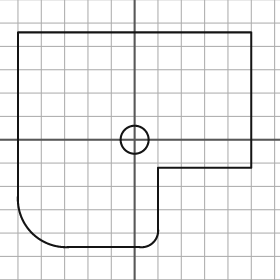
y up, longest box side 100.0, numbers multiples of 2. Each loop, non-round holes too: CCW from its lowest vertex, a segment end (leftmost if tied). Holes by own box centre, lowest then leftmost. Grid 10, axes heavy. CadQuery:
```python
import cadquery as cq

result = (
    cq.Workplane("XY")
    .moveTo(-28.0, -46.0)
    .lineTo(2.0, -46.0)
    .threePointArc((8.0, -44.0), (10.0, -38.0))
    .lineTo(10.0, -12.0)
    .lineTo(50.0, -12.0)
    .lineTo(50.0, 46.0)
    .lineTo(-50.0, 46.0)
    .lineTo(-50.0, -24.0)
    .threePointArc((-44.0, -40.0), (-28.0, -46.0))
    .close()
    .moveTo(0.0, 0.0)
    .circle(6.0)
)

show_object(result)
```